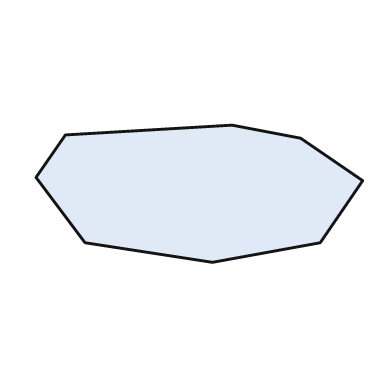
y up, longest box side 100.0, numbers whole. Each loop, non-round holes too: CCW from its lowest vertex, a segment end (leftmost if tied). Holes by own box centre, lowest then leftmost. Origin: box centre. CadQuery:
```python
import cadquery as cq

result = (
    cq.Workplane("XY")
    .moveTo(4.0, -21.0)
    .lineTo(37.0, -15.0)
    .lineTo(50.0, 4.0)
    .lineTo(31.0, 17.0)
    .lineTo(10.0, 21.0)
    .lineTo(-41.0, 18.0)
    .lineTo(-50.0, 5.0)
    .lineTo(-35.0, -15.0)
    .close()
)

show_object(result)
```